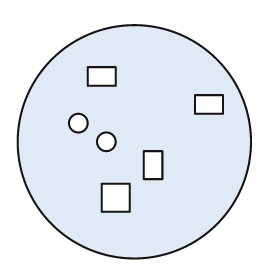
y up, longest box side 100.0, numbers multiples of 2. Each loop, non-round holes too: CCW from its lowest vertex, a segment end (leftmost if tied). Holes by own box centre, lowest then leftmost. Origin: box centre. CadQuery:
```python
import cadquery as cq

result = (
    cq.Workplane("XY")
    .moveTo(0.0, 0.0)
    .circle(50.0)
    .moveTo(-14.0, -30.0)
    .lineTo(-2.0, -30.0)
    .lineTo(-2.0, -18.0)
    .lineTo(-14.0, -18.0)
    .close()
    .moveTo(4.0, -16.0)
    .lineTo(12.0, -16.0)
    .lineTo(12.0, -4.0)
    .lineTo(4.0, -4.0)
    .close()
    .moveTo(-12.0, 0.0)
    .circle(4.0)
    .moveTo(-24.0, 8.0)
    .circle(4.0)
    .moveTo(26.0, 12.0)
    .lineTo(38.0, 12.0)
    .lineTo(38.0, 20.0)
    .lineTo(26.0, 20.0)
    .close()
    .moveTo(-20.0, 24.0)
    .lineTo(-8.0, 24.0)
    .lineTo(-8.0, 32.0)
    .lineTo(-20.0, 32.0)
    .close()
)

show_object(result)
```